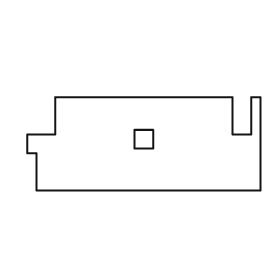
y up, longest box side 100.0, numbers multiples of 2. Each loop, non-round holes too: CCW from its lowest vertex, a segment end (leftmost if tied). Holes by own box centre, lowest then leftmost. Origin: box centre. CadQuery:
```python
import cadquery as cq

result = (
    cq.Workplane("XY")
    .moveTo(-46.0, -20.0)
    .lineTo(50.0, -20.0)
    .lineTo(50.0, 20.0)
    .lineTo(46.0, 20.0)
    .lineTo(46.0, 4.0)
    .lineTo(38.0, 4.0)
    .lineTo(38.0, 20.0)
    .lineTo(-38.0, 20.0)
    .lineTo(-38.0, 4.0)
    .lineTo(-50.0, 4.0)
    .lineTo(-50.0, -4.0)
    .lineTo(-46.0, -4.0)
    .close()
    .moveTo(-4.0, -2.0)
    .lineTo(4.0, -2.0)
    .lineTo(4.0, 6.0)
    .lineTo(-4.0, 6.0)
    .close()
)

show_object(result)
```